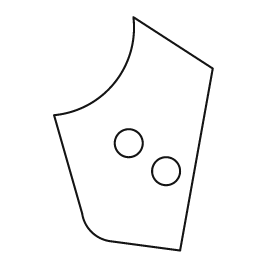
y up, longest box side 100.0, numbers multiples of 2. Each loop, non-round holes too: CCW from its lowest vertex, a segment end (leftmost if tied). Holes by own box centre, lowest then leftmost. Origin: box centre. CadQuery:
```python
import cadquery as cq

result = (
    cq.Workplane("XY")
    .moveTo(20.0, -50.0)
    .lineTo(34.0, 28.0)
    .lineTo(0.0, 50.0)
    .threePointArc((-8.0, 22.0), (-34.0, 8.0))
    .lineTo(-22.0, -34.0)
    .threePointArc((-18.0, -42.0), (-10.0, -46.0))
    .close()
    .moveTo(14.0, -16.0)
    .circle(6.0)
    .moveTo(-2.0, -4.0)
    .circle(6.0)
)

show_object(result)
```